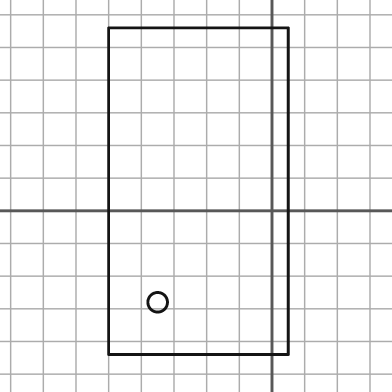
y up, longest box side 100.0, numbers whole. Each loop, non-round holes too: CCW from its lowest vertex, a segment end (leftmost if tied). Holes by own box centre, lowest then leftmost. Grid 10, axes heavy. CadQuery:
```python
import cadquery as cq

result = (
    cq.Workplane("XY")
    .moveTo(-50.0, -44.0)
    .lineTo(5.0, -44.0)
    .lineTo(5.0, 56.0)
    .lineTo(-50.0, 56.0)
    .close()
    .moveTo(-35.0, -28.0)
    .circle(3.0)
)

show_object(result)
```